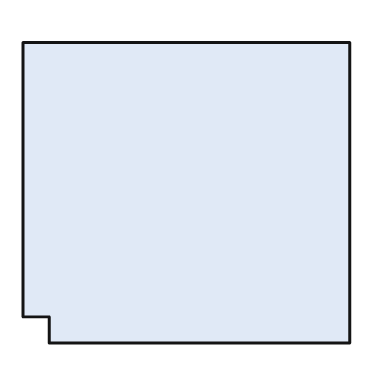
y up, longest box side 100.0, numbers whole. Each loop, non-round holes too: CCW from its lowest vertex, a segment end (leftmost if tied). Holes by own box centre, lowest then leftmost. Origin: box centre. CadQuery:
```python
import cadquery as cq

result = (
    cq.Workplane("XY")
    .moveTo(-42.0, -46.0)
    .lineTo(50.0, -46.0)
    .lineTo(50.0, 46.0)
    .lineTo(-50.0, 46.0)
    .lineTo(-50.0, -38.0)
    .lineTo(-42.0, -38.0)
    .close()
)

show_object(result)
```